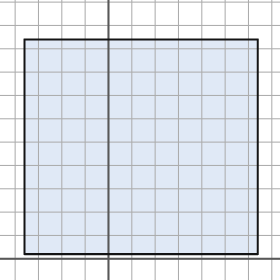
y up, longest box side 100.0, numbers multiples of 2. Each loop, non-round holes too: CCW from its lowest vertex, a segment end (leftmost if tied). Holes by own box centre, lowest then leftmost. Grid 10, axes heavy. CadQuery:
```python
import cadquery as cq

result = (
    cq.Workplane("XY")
    .moveTo(-36.0, 2.0)
    .lineTo(64.0, 2.0)
    .lineTo(64.0, 94.0)
    .lineTo(-36.0, 94.0)
    .close()
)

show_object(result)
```